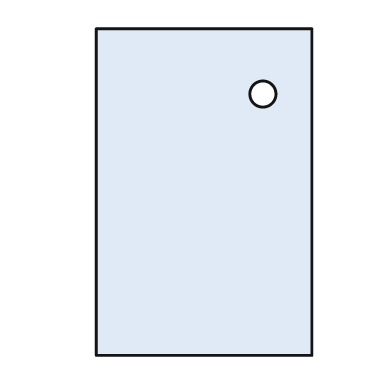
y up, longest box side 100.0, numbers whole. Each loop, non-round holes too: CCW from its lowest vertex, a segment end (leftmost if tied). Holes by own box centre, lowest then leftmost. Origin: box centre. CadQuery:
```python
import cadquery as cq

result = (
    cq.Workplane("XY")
    .moveTo(-33.0, -50.0)
    .lineTo(33.0, -50.0)
    .lineTo(33.0, 50.0)
    .lineTo(-33.0, 50.0)
    .close()
    .moveTo(18.0, 30.0)
    .circle(4.0)
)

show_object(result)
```